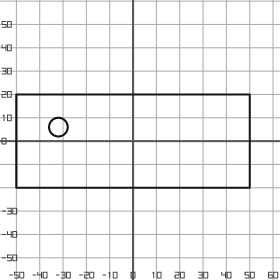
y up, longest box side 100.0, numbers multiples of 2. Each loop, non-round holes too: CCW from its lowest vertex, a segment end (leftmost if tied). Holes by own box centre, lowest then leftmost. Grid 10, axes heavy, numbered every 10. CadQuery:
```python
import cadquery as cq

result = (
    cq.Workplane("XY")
    .moveTo(-50.0, -20.0)
    .lineTo(50.0, -20.0)
    .lineTo(50.0, 20.0)
    .lineTo(-50.0, 20.0)
    .close()
    .moveTo(-32.0, 6.0)
    .circle(4.0)
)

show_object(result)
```